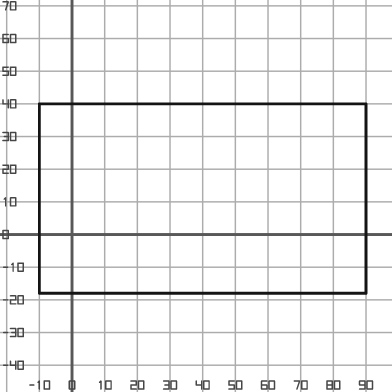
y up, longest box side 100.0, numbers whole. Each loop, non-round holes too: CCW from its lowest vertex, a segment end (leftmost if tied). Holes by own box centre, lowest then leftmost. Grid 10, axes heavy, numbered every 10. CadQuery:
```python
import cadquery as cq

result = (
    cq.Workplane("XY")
    .moveTo(-10.0, -18.0)
    .lineTo(90.0, -18.0)
    .lineTo(90.0, 40.0)
    .lineTo(-10.0, 40.0)
    .close()
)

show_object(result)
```